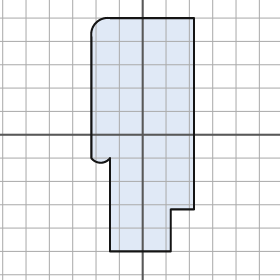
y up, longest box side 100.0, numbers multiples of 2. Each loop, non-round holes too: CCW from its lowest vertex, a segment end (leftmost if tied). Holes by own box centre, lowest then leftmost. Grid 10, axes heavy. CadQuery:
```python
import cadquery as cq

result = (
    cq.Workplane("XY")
    .moveTo(-14.0, -50.0)
    .lineTo(12.0, -50.0)
    .lineTo(12.0, -32.0)
    .lineTo(22.0, -32.0)
    .lineTo(22.0, 50.0)
    .lineTo(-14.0, 50.0)
    .threePointArc((-20.0, 48.0), (-22.0, 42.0))
    .lineTo(-22.0, -10.0)
    .threePointArc((-18.0, -12.0), (-14.0, -10.0))
    .close()
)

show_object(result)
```